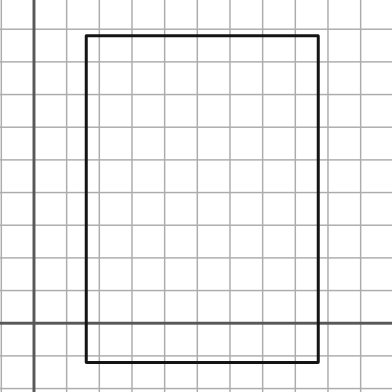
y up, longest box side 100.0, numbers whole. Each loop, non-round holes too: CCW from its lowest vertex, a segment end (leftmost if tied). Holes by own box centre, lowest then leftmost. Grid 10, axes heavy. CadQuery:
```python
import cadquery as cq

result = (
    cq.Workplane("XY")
    .moveTo(16.0, -12.0)
    .lineTo(87.0, -12.0)
    .lineTo(87.0, 88.0)
    .lineTo(16.0, 88.0)
    .close()
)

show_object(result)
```